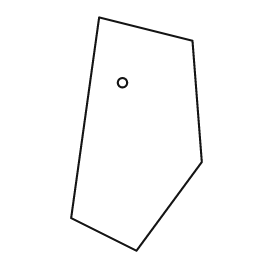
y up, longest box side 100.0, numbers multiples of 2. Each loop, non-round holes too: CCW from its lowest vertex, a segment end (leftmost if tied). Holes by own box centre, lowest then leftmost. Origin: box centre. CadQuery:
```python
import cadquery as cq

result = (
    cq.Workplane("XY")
    .moveTo(0.0, -50.0)
    .lineTo(28.0, -12.0)
    .lineTo(24.0, 40.0)
    .lineTo(-16.0, 50.0)
    .lineTo(-28.0, -36.0)
    .close()
    .moveTo(-6.0, 22.0)
    .circle(2.0)
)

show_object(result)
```